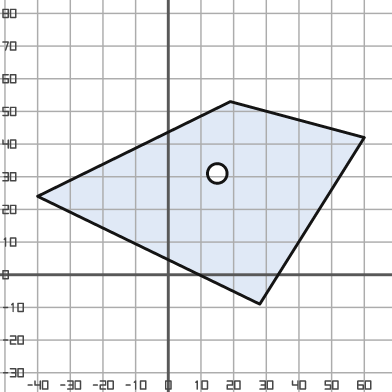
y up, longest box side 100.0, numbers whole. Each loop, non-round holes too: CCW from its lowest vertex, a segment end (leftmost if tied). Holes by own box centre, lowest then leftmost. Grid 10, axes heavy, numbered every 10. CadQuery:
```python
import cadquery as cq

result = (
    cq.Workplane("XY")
    .moveTo(28.0, -9.0)
    .lineTo(60.0, 42.0)
    .lineTo(19.0, 53.0)
    .lineTo(-40.0, 24.0)
    .close()
    .moveTo(15.0, 31.0)
    .circle(3.0)
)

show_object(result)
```